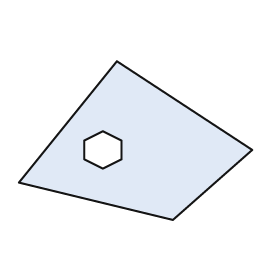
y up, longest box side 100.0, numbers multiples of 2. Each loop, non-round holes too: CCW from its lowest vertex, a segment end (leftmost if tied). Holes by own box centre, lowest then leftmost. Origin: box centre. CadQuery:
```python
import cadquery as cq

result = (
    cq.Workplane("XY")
    .moveTo(16.0, -34.0)
    .lineTo(50.0, -4.0)
    .lineTo(-8.0, 34.0)
    .lineTo(-50.0, -18.0)
    .close()
    .moveTo(-14.0, -12.0)
    .lineTo(-6.0, -8.0)
    .lineTo(-6.0, 0.0)
    .lineTo(-14.0, 4.0)
    .lineTo(-22.0, 0.0)
    .lineTo(-22.0, -8.0)
    .close()
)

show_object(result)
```